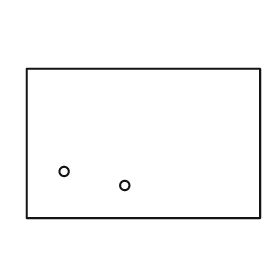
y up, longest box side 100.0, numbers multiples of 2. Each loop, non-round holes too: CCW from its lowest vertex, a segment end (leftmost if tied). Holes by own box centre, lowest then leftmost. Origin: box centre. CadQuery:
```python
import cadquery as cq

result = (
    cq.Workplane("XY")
    .moveTo(-50.0, -32.0)
    .lineTo(50.0, -32.0)
    .lineTo(50.0, 32.0)
    .lineTo(-50.0, 32.0)
    .close()
    .moveTo(-8.0, -18.0)
    .circle(2.0)
    .moveTo(-34.0, -12.0)
    .circle(2.0)
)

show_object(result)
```